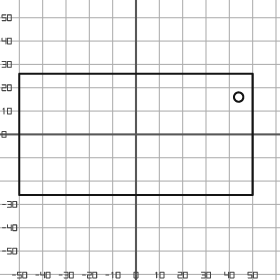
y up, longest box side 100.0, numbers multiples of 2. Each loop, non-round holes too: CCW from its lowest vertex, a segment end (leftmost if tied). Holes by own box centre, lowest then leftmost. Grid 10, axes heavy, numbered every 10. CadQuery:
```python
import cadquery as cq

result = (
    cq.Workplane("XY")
    .moveTo(-50.0, -26.0)
    .lineTo(50.0, -26.0)
    .lineTo(50.0, 26.0)
    .lineTo(-50.0, 26.0)
    .close()
    .moveTo(44.0, 16.0)
    .circle(2.0)
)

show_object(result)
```